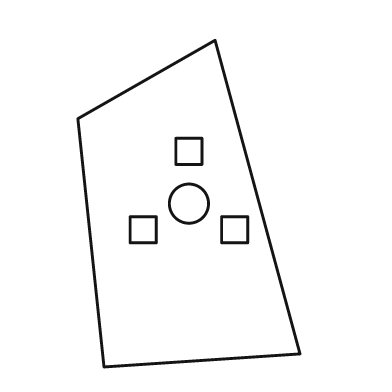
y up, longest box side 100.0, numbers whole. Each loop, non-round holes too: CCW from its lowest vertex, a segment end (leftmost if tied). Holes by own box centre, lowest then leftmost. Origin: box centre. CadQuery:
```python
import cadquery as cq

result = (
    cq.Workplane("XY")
    .moveTo(-26.0, -50.0)
    .lineTo(34.0, -46.0)
    .lineTo(8.0, 50.0)
    .lineTo(-34.0, 26.0)
    .close()
    .moveTo(-18.0, -12.0)
    .lineTo(-10.0, -12.0)
    .lineTo(-10.0, -4.0)
    .lineTo(-18.0, -4.0)
    .close()
    .moveTo(10.0, -12.0)
    .lineTo(18.0, -12.0)
    .lineTo(18.0, -4.0)
    .lineTo(10.0, -4.0)
    .close()
    .moveTo(0.0, 0.0)
    .circle(6.0)
    .moveTo(-4.0, 12.0)
    .lineTo(4.0, 12.0)
    .lineTo(4.0, 20.0)
    .lineTo(-4.0, 20.0)
    .close()
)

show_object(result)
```